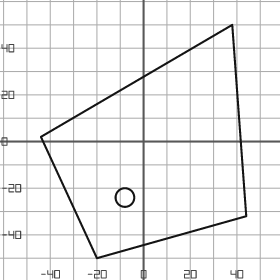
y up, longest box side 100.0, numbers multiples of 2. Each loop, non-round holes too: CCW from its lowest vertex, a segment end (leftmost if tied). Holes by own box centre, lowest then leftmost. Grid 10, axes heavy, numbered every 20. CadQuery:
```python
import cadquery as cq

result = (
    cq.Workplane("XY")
    .moveTo(-20.0, -50.0)
    .lineTo(44.0, -32.0)
    .lineTo(38.0, 50.0)
    .lineTo(-44.0, 2.0)
    .close()
    .moveTo(-8.0, -24.0)
    .circle(4.0)
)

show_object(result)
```